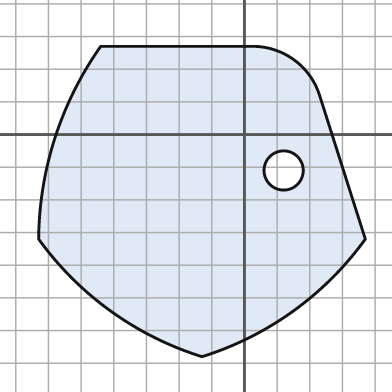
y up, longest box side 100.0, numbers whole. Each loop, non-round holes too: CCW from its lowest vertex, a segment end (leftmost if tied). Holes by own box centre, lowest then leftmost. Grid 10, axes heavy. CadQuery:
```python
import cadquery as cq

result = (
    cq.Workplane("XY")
    .moveTo(-13.0, -68.0)
    .threePointArc((15.0, -54.0), (37.0, -32.0))
    .lineTo(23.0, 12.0)
    .threePointArc((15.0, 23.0), (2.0, 27.0))
    .lineTo(-44.0, 27.0)
    .threePointArc((-58.0, -1.0), (-63.0, -32.0))
    .threePointArc((-41.0, -54.0), (-13.0, -68.0))
    .close()
    .moveTo(12.0, -11.0)
    .circle(6.0)
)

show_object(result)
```